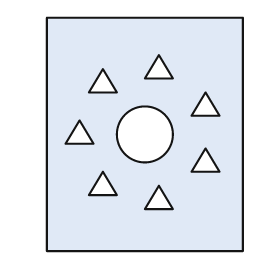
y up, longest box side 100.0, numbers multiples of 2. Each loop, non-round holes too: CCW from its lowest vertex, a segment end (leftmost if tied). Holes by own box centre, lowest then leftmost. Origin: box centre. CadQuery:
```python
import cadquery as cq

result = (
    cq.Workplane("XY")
    .moveTo(-42.0, -50.0)
    .lineTo(42.0, -50.0)
    .lineTo(42.0, 50.0)
    .lineTo(-42.0, 50.0)
    .close()
    .moveTo(0.0, -32.0)
    .lineTo(12.0, -32.0)
    .lineTo(6.0, -22.0)
    .close()
    .moveTo(-24.0, -26.0)
    .lineTo(-12.0, -26.0)
    .lineTo(-18.0, -16.0)
    .close()
    .moveTo(20.0, -16.0)
    .lineTo(32.0, -16.0)
    .lineTo(26.0, -6.0)
    .close()
    .moveTo(0.0, 0.0)
    .circle(12.0)
    .moveTo(-34.0, -4.0)
    .lineTo(-22.0, -4.0)
    .lineTo(-28.0, 6.0)
    .close()
    .moveTo(20.0, 8.0)
    .lineTo(32.0, 8.0)
    .lineTo(26.0, 18.0)
    .close()
    .moveTo(-24.0, 18.0)
    .lineTo(-12.0, 18.0)
    .lineTo(-18.0, 28.0)
    .close()
    .moveTo(0.0, 24.0)
    .lineTo(12.0, 24.0)
    .lineTo(6.0, 34.0)
    .close()
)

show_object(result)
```